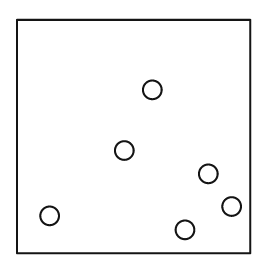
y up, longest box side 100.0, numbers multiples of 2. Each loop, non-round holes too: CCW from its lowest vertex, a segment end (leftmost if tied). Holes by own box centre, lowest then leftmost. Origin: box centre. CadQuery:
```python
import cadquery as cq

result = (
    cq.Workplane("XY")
    .moveTo(-50.0, -50.0)
    .lineTo(50.0, -50.0)
    .lineTo(50.0, 50.0)
    .lineTo(-50.0, 50.0)
    .close()
    .moveTo(22.0, -40.0)
    .circle(4.0)
    .moveTo(-36.0, -34.0)
    .circle(4.0)
    .moveTo(42.0, -30.0)
    .circle(4.0)
    .moveTo(32.0, -16.0)
    .circle(4.0)
    .moveTo(-4.0, -6.0)
    .circle(4.0)
    .moveTo(8.0, 20.0)
    .circle(4.0)
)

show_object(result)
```